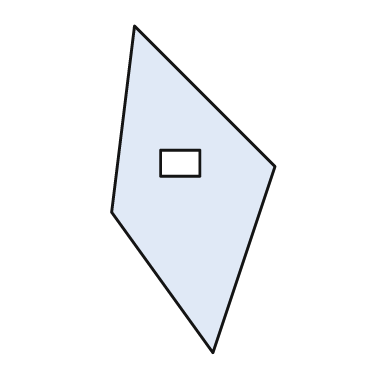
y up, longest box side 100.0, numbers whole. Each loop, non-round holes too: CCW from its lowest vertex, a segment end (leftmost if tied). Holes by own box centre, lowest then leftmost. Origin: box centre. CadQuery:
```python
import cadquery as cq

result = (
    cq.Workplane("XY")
    .moveTo(6.0, -50.0)
    .lineTo(25.0, 7.0)
    .lineTo(-18.0, 50.0)
    .lineTo(-25.0, -7.0)
    .close()
    .moveTo(-10.0, 4.0)
    .lineTo(2.0, 4.0)
    .lineTo(2.0, 12.0)
    .lineTo(-10.0, 12.0)
    .close()
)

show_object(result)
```